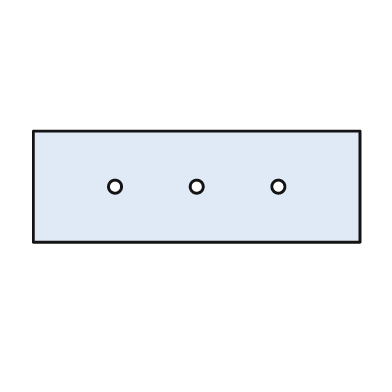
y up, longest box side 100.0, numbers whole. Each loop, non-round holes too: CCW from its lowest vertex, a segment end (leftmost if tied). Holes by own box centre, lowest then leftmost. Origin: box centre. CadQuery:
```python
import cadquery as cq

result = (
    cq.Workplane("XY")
    .moveTo(-50.0, -17.0)
    .lineTo(50.0, -17.0)
    .lineTo(50.0, 17.0)
    .lineTo(-50.0, 17.0)
    .close()
    .moveTo(-25.0, 0.0)
    .circle(2.0)
    .moveTo(0.0, 0.0)
    .circle(2.0)
    .moveTo(25.0, 0.0)
    .circle(2.0)
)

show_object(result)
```